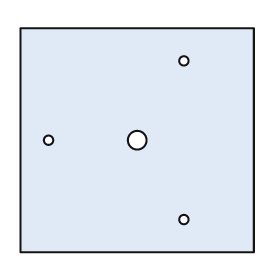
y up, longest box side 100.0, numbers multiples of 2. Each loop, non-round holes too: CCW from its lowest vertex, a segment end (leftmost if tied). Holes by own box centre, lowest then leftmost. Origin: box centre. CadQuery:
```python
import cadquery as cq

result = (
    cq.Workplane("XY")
    .moveTo(-50.0, -48.0)
    .lineTo(50.0, -48.0)
    .lineTo(50.0, 48.0)
    .lineTo(-50.0, 48.0)
    .close()
    .moveTo(20.0, -34.0)
    .circle(2.0)
    .moveTo(-38.0, 0.0)
    .circle(2.0)
    .moveTo(0.0, 0.0)
    .circle(4.0)
    .moveTo(20.0, 34.0)
    .circle(2.0)
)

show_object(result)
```